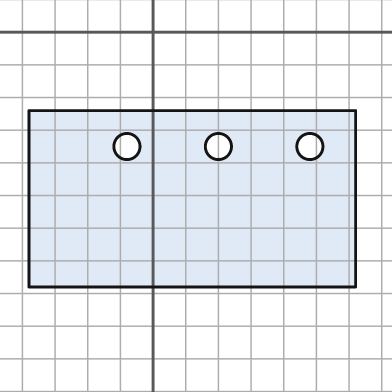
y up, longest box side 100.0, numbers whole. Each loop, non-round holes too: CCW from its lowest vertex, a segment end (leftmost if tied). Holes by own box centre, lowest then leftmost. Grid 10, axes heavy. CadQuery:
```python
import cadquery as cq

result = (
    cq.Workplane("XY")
    .moveTo(-38.0, -78.0)
    .lineTo(62.0, -78.0)
    .lineTo(62.0, -24.0)
    .lineTo(-38.0, -24.0)
    .close()
    .moveTo(-8.0, -35.0)
    .circle(4.0)
    .moveTo(20.0, -35.0)
    .circle(4.0)
    .moveTo(48.0, -35.0)
    .circle(4.0)
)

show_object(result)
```